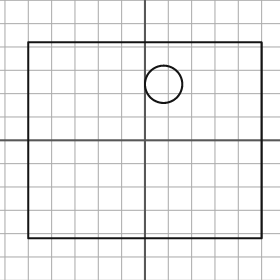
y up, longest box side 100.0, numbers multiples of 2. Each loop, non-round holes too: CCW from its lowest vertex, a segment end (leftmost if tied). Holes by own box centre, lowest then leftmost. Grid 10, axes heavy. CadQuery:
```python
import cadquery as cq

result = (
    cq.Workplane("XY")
    .moveTo(-50.0, -42.0)
    .lineTo(50.0, -42.0)
    .lineTo(50.0, 42.0)
    .lineTo(-50.0, 42.0)
    .close()
    .moveTo(8.0, 24.0)
    .circle(8.0)
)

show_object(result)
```